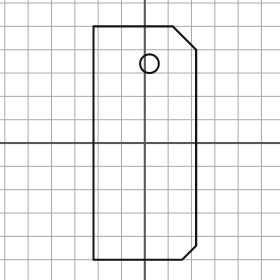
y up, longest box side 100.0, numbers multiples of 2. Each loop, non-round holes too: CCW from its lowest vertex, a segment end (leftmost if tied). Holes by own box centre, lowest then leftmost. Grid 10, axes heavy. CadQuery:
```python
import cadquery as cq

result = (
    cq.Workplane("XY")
    .moveTo(-22.0, -50.0)
    .lineTo(16.0, -50.0)
    .lineTo(22.0, -44.0)
    .lineTo(22.0, 40.0)
    .lineTo(12.0, 50.0)
    .lineTo(-22.0, 50.0)
    .close()
    .moveTo(2.0, 34.0)
    .circle(4.0)
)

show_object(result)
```